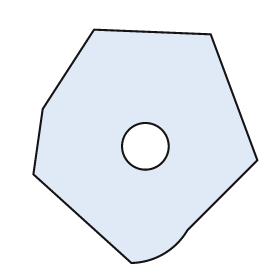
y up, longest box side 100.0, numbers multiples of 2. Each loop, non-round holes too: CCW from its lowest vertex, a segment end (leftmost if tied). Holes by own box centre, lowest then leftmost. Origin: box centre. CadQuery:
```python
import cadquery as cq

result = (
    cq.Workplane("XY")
    .moveTo(-6.0, -50.0)
    .threePointArc((8.0, -46.0), (18.0, -36.0))
    .lineTo(48.0, -6.0)
    .lineTo(28.0, 48.0)
    .lineTo(-22.0, 50.0)
    .lineTo(-44.0, 16.0)
    .lineTo(-48.0, -12.0)
    .close()
    .moveTo(0.0, 0.0)
    .circle(10.0)
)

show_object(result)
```